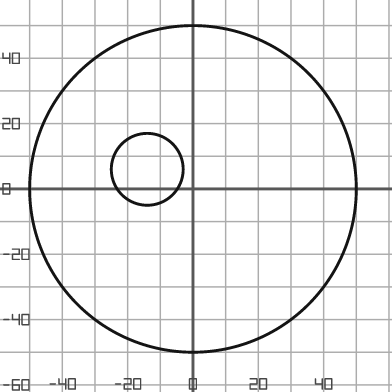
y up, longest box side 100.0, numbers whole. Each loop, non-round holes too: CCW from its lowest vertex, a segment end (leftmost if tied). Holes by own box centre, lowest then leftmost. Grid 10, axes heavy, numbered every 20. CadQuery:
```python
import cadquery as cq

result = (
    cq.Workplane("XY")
    .moveTo(0.0, 0.0)
    .circle(50.0)
    .moveTo(-14.0, 6.0)
    .circle(11.0)
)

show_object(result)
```